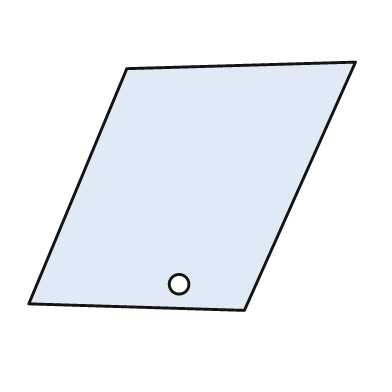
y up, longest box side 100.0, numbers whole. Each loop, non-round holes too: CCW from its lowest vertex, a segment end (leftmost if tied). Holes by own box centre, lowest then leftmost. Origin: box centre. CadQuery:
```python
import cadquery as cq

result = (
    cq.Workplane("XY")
    .moveTo(16.0, -38.0)
    .lineTo(50.0, 38.0)
    .lineTo(-20.0, 36.0)
    .lineTo(-50.0, -36.0)
    .close()
    .moveTo(-4.0, -30.0)
    .circle(3.0)
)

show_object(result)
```